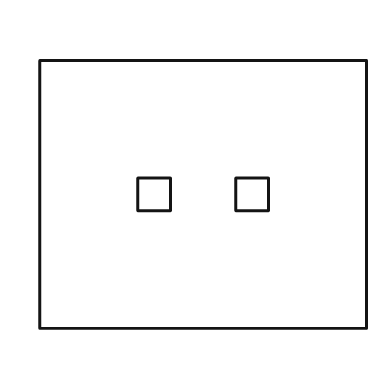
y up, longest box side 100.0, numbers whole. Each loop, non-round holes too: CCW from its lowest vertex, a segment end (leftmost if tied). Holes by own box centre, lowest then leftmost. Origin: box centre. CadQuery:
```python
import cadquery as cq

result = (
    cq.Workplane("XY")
    .moveTo(-50.0, -41.0)
    .lineTo(50.0, -41.0)
    .lineTo(50.0, 41.0)
    .lineTo(-50.0, 41.0)
    .close()
    .moveTo(-20.0, -5.0)
    .lineTo(-10.0, -5.0)
    .lineTo(-10.0, 5.0)
    .lineTo(-20.0, 5.0)
    .close()
    .moveTo(10.0, -5.0)
    .lineTo(20.0, -5.0)
    .lineTo(20.0, 5.0)
    .lineTo(10.0, 5.0)
    .close()
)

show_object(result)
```